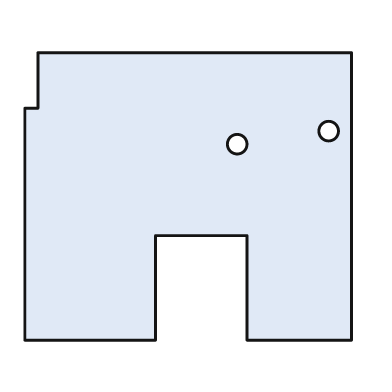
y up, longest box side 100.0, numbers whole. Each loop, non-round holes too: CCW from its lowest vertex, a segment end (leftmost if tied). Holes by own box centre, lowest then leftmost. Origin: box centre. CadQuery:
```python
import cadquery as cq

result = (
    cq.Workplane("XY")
    .moveTo(-50.0, -44.0)
    .lineTo(-10.0, -44.0)
    .lineTo(-10.0, -12.0)
    .lineTo(18.0, -12.0)
    .lineTo(18.0, -44.0)
    .lineTo(50.0, -44.0)
    .lineTo(50.0, 44.0)
    .lineTo(-46.0, 44.0)
    .lineTo(-46.0, 27.0)
    .lineTo(-50.0, 27.0)
    .close()
    .moveTo(15.0, 16.0)
    .circle(3.0)
    .moveTo(43.0, 20.0)
    .circle(3.0)
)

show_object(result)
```